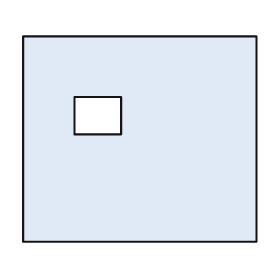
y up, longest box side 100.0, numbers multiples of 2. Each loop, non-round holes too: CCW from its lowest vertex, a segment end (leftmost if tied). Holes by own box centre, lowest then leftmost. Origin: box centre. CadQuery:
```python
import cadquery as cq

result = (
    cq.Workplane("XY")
    .moveTo(-50.0, -44.0)
    .lineTo(50.0, -44.0)
    .lineTo(50.0, 44.0)
    .lineTo(-50.0, 44.0)
    .close()
    .moveTo(-28.0, 2.0)
    .lineTo(-8.0, 2.0)
    .lineTo(-8.0, 18.0)
    .lineTo(-28.0, 18.0)
    .close()
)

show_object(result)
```